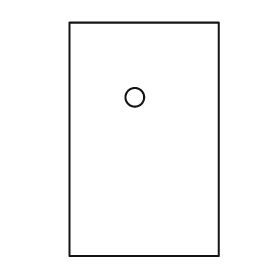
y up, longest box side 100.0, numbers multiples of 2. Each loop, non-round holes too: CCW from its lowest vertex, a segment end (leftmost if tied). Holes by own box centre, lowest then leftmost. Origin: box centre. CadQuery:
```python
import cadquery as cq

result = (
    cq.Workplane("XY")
    .moveTo(-32.0, -50.0)
    .lineTo(32.0, -50.0)
    .lineTo(32.0, 50.0)
    .lineTo(-32.0, 50.0)
    .close()
    .moveTo(-4.0, 18.0)
    .circle(4.0)
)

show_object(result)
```